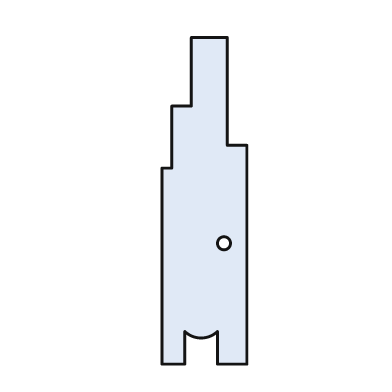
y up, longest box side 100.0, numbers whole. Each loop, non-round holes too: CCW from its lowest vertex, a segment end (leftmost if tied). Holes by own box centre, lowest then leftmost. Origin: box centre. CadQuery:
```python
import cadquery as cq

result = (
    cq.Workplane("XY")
    .moveTo(-13.0, -50.0)
    .lineTo(-6.0, -50.0)
    .lineTo(-6.0, -40.0)
    .threePointArc((-1.0, -42.0), (4.0, -40.0))
    .lineTo(4.0, -50.0)
    .lineTo(13.0, -50.0)
    .lineTo(13.0, 17.0)
    .lineTo(7.0, 17.0)
    .lineTo(7.0, 50.0)
    .lineTo(-4.0, 50.0)
    .lineTo(-4.0, 29.0)
    .lineTo(-10.0, 29.0)
    .lineTo(-10.0, 10.0)
    .lineTo(-13.0, 10.0)
    .close()
    .moveTo(6.0, -13.0)
    .circle(2.0)
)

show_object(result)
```